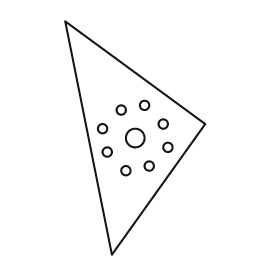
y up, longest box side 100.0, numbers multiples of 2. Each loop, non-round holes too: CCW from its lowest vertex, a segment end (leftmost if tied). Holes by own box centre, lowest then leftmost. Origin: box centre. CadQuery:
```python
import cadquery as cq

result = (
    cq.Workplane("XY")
    .moveTo(-10.0, -50.0)
    .lineTo(30.0, 6.0)
    .lineTo(-30.0, 50.0)
    .close()
    .moveTo(-4.0, -14.0)
    .circle(2.0)
    .moveTo(6.0, -12.0)
    .circle(2.0)
    .moveTo(-12.0, -6.0)
    .circle(2.0)
    .moveTo(14.0, -4.0)
    .circle(2.0)
    .moveTo(0.0, 0.0)
    .circle(4.0)
    .moveTo(-14.0, 4.0)
    .circle(2.0)
    .moveTo(12.0, 6.0)
    .circle(2.0)
    .moveTo(-6.0, 12.0)
    .circle(2.0)
    .moveTo(4.0, 14.0)
    .circle(2.0)
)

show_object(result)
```